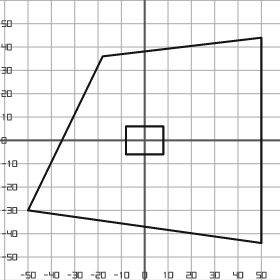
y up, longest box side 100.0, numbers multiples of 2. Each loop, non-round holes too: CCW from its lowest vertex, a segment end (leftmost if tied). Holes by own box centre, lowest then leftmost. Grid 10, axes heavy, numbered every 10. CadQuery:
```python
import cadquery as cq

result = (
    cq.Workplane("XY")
    .moveTo(50.0, -44.0)
    .lineTo(50.0, 44.0)
    .lineTo(-18.0, 36.0)
    .lineTo(-50.0, -30.0)
    .close()
    .moveTo(-8.0, -6.0)
    .lineTo(8.0, -6.0)
    .lineTo(8.0, 6.0)
    .lineTo(-8.0, 6.0)
    .close()
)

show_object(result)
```